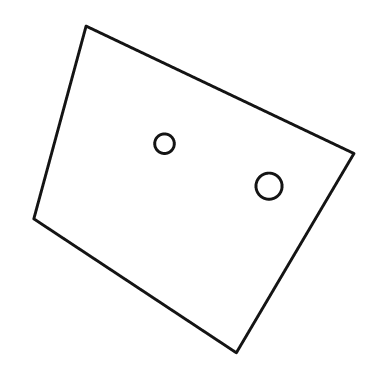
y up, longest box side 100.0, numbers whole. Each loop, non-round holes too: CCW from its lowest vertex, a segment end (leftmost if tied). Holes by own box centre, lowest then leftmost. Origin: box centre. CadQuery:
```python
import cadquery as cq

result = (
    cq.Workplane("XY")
    .moveTo(13.0, -50.0)
    .lineTo(49.0, 11.0)
    .lineTo(-33.0, 50.0)
    .lineTo(-49.0, -9.0)
    .close()
    .moveTo(23.0, 1.0)
    .circle(4.0)
    .moveTo(-9.0, 14.0)
    .circle(3.0)
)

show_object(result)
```